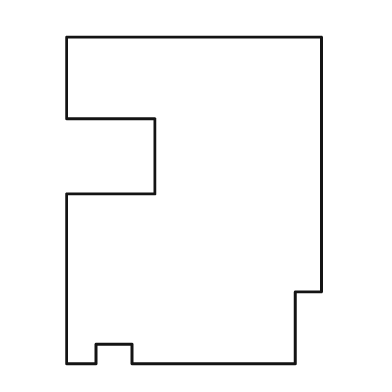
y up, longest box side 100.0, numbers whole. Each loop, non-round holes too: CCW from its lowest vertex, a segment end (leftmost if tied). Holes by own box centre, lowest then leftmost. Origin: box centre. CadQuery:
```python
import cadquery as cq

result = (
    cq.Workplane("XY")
    .moveTo(-39.0, -50.0)
    .lineTo(-30.0, -50.0)
    .lineTo(-30.0, -44.0)
    .lineTo(-19.0, -44.0)
    .lineTo(-19.0, -50.0)
    .lineTo(31.0, -50.0)
    .lineTo(31.0, -28.0)
    .lineTo(39.0, -28.0)
    .lineTo(39.0, 50.0)
    .lineTo(-39.0, 50.0)
    .lineTo(-39.0, 25.0)
    .lineTo(-12.0, 25.0)
    .lineTo(-12.0, 2.0)
    .lineTo(-39.0, 2.0)
    .close()
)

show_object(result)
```